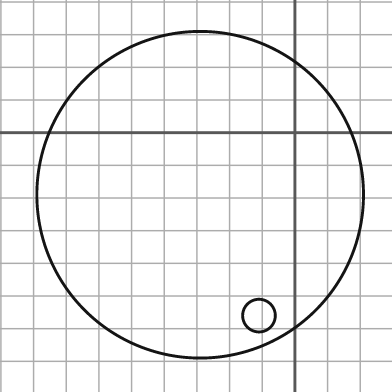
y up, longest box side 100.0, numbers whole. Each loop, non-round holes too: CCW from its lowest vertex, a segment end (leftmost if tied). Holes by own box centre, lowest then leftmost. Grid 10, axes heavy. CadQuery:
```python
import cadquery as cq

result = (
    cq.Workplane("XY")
    .moveTo(-29.0, -19.0)
    .circle(50.0)
    .moveTo(-11.0, -56.0)
    .circle(5.0)
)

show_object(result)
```